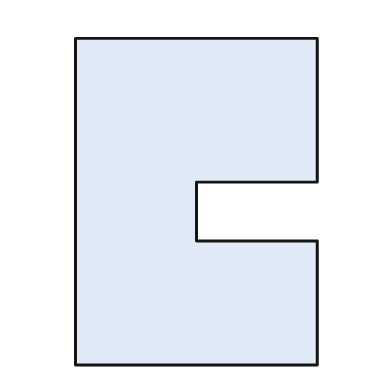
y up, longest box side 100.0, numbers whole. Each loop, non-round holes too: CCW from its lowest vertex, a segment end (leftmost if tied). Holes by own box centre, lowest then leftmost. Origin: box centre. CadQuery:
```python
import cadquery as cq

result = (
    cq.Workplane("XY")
    .moveTo(-37.0, -50.0)
    .lineTo(37.0, -50.0)
    .lineTo(37.0, -12.0)
    .lineTo(0.0, -12.0)
    .lineTo(0.0, 6.0)
    .lineTo(37.0, 6.0)
    .lineTo(37.0, 50.0)
    .lineTo(-37.0, 50.0)
    .close()
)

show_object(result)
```